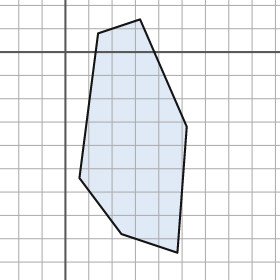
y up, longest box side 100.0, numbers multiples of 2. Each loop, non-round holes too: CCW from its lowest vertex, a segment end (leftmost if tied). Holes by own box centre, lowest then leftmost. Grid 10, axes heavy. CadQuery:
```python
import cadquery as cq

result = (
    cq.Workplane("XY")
    .moveTo(48.0, -86.0)
    .lineTo(52.0, -32.0)
    .lineTo(32.0, 14.0)
    .lineTo(14.0, 8.0)
    .lineTo(6.0, -54.0)
    .lineTo(24.0, -78.0)
    .close()
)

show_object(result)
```